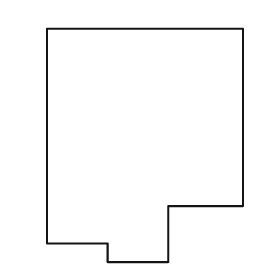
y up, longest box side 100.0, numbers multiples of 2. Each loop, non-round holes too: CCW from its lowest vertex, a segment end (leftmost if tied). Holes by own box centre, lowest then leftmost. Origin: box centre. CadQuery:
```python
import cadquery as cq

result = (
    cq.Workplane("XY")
    .moveTo(-16.0, -50.0)
    .lineTo(10.0, -50.0)
    .lineTo(10.0, -26.0)
    .lineTo(42.0, -26.0)
    .lineTo(42.0, 50.0)
    .lineTo(-42.0, 50.0)
    .lineTo(-42.0, -42.0)
    .lineTo(-16.0, -42.0)
    .close()
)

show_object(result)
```